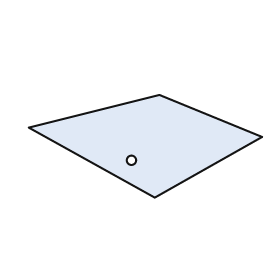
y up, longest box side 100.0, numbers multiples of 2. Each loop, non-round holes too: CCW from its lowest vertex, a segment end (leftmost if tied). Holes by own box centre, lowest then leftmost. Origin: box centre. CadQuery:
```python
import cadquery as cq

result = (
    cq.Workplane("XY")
    .moveTo(4.0, -22.0)
    .lineTo(50.0, 4.0)
    .lineTo(6.0, 22.0)
    .lineTo(-50.0, 8.0)
    .close()
    .moveTo(-6.0, -6.0)
    .circle(2.0)
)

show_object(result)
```